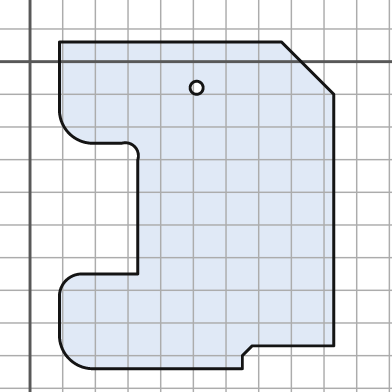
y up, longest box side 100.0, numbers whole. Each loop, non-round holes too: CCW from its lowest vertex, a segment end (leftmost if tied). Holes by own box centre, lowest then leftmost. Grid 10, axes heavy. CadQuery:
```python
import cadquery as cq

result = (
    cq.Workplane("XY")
    .moveTo(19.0, -94.0)
    .lineTo(65.0, -94.0)
    .lineTo(65.0, -90.0)
    .lineTo(68.0, -87.0)
    .lineTo(93.0, -87.0)
    .lineTo(93.0, -10.0)
    .lineTo(77.0, 6.0)
    .lineTo(9.0, 6.0)
    .lineTo(9.0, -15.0)
    .threePointArc((12.0, -22.0), (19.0, -25.0))
    .lineTo(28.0, -25.0)
    .threePointArc((32.0, -26.0), (33.0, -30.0))
    .lineTo(33.0, -65.0)
    .lineTo(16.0, -65.0)
    .threePointArc((11.0, -67.0), (9.0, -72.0))
    .lineTo(9.0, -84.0)
    .threePointArc((12.0, -91.0), (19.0, -94.0))
    .close()
    .moveTo(51.0, -8.0)
    .circle(2.0)
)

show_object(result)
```